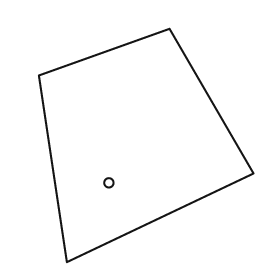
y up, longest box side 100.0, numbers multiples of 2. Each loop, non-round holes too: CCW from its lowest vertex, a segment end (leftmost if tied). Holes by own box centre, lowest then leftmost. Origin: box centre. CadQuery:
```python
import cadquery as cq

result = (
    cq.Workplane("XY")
    .moveTo(-34.0, -50.0)
    .lineTo(46.0, -12.0)
    .lineTo(10.0, 50.0)
    .lineTo(-46.0, 30.0)
    .close()
    .moveTo(-16.0, -16.0)
    .circle(2.0)
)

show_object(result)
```